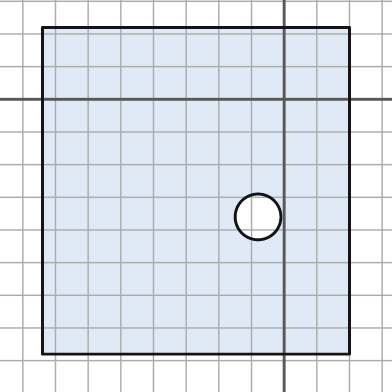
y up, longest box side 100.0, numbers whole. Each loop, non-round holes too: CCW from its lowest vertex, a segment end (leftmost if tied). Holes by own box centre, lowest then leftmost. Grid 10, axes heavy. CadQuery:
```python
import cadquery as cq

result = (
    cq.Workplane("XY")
    .moveTo(-74.0, -78.0)
    .lineTo(20.0, -78.0)
    .lineTo(20.0, 22.0)
    .lineTo(-74.0, 22.0)
    .close()
    .moveTo(-8.0, -36.0)
    .circle(7.0)
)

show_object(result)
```